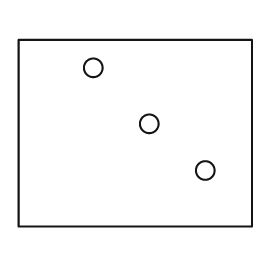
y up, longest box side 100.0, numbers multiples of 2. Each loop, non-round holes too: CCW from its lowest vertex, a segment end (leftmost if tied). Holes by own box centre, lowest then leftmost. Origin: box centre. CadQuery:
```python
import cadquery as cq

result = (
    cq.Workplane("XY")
    .moveTo(-50.0, -40.0)
    .lineTo(50.0, -40.0)
    .lineTo(50.0, 40.0)
    .lineTo(-50.0, 40.0)
    .close()
    .moveTo(30.0, -16.0)
    .circle(4.0)
    .moveTo(6.0, 4.0)
    .circle(4.0)
    .moveTo(-18.0, 28.0)
    .circle(4.0)
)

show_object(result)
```